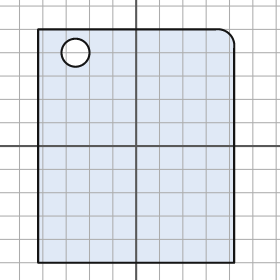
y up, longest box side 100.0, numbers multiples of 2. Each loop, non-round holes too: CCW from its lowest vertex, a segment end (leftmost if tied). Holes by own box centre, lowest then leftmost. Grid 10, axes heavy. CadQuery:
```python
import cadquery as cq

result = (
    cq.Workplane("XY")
    .moveTo(-42.0, -50.0)
    .lineTo(42.0, -50.0)
    .lineTo(42.0, 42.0)
    .threePointArc((40.0, 48.0), (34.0, 50.0))
    .lineTo(-42.0, 50.0)
    .close()
    .moveTo(-26.0, 40.0)
    .circle(6.0)
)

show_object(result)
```